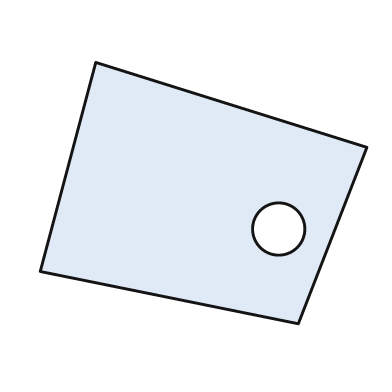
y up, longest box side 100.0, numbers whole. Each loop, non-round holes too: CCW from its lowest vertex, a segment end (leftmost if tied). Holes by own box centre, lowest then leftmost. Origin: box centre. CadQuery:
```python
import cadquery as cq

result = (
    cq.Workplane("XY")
    .moveTo(29.0, -40.0)
    .lineTo(50.0, 14.0)
    .lineTo(-33.0, 40.0)
    .lineTo(-50.0, -24.0)
    .close()
    .moveTo(23.0, -11.0)
    .circle(8.0)
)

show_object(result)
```